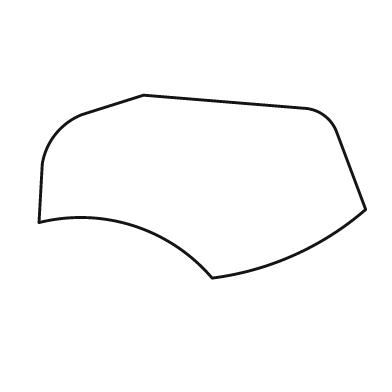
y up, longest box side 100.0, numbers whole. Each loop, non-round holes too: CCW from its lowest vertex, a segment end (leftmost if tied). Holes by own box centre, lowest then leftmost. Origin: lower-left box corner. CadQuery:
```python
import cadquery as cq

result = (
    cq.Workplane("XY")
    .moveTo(53.0, 0.0)
    .threePointArc((78.0, 7.0), (100.0, 21.0))
    .lineTo(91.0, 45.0)
    .threePointArc((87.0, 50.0), (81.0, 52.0))
    .lineTo(32.0, 56.0)
    .lineTo(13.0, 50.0)
    .threePointArc((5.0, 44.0), (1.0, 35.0))
    .lineTo(0.0, 17.0)
    .threePointArc((29.0, 16.0), (53.0, 0.0))
    .close()
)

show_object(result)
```